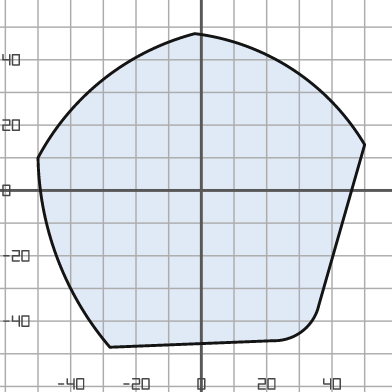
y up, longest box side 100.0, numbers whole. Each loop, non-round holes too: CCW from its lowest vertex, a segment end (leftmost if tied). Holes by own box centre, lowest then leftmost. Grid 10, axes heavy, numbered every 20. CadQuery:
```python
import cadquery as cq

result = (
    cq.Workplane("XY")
    .moveTo(-28.0, -48.0)
    .lineTo(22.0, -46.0)
    .threePointArc((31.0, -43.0), (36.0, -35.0))
    .lineTo(50.0, 14.0)
    .threePointArc((28.0, 37.0), (-2.0, 48.0))
    .threePointArc((-30.0, 34.0), (-50.0, 10.0))
    .threePointArc((-44.0, -21.0), (-28.0, -48.0))
    .close()
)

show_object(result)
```